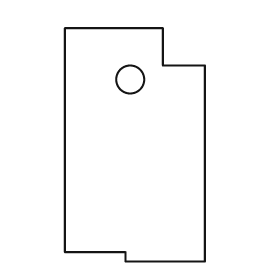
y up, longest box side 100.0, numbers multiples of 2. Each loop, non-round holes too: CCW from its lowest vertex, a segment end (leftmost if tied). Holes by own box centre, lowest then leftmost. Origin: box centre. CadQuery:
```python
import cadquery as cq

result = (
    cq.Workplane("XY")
    .moveTo(-4.0, -50.0)
    .lineTo(30.0, -50.0)
    .lineTo(30.0, 34.0)
    .lineTo(12.0, 34.0)
    .lineTo(12.0, 50.0)
    .lineTo(-30.0, 50.0)
    .lineTo(-30.0, -46.0)
    .lineTo(-4.0, -46.0)
    .close()
    .moveTo(-2.0, 28.0)
    .circle(6.0)
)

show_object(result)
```